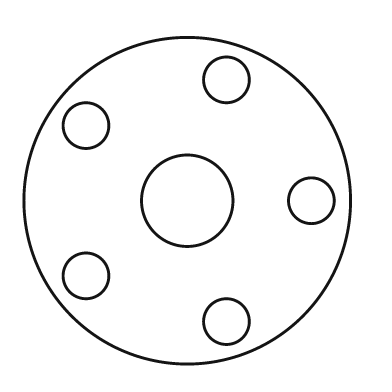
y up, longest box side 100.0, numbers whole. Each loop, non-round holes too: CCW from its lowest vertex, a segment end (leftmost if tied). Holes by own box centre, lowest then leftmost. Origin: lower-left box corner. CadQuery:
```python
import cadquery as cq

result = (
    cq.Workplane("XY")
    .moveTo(50.0, 50.0)
    .circle(50.0)
    .moveTo(62.0, 13.0)
    .circle(7.0)
    .moveTo(19.0, 27.0)
    .circle(7.0)
    .moveTo(50.0, 50.0)
    .circle(14.0)
    .moveTo(88.0, 50.0)
    .circle(7.0)
    .moveTo(19.0, 73.0)
    .circle(7.0)
    .moveTo(62.0, 87.0)
    .circle(7.0)
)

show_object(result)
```